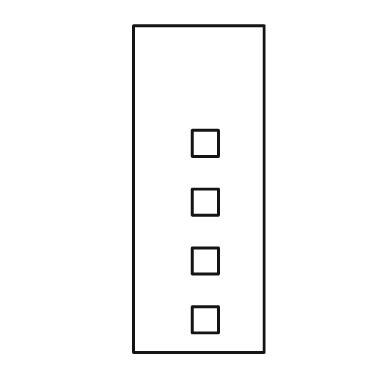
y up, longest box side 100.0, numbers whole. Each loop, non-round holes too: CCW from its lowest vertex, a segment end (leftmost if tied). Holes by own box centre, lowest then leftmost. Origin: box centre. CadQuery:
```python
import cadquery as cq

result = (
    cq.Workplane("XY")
    .moveTo(-20.0, -50.0)
    .lineTo(20.0, -50.0)
    .lineTo(20.0, 50.0)
    .lineTo(-20.0, 50.0)
    .close()
    .moveTo(-2.0, -44.0)
    .lineTo(6.0, -44.0)
    .lineTo(6.0, -36.0)
    .lineTo(-2.0, -36.0)
    .close()
    .moveTo(-2.0, -26.0)
    .lineTo(6.0, -26.0)
    .lineTo(6.0, -18.0)
    .lineTo(-2.0, -18.0)
    .close()
    .moveTo(-2.0, -8.0)
    .lineTo(6.0, -8.0)
    .lineTo(6.0, 0.0)
    .lineTo(-2.0, 0.0)
    .close()
    .moveTo(-2.0, 10.0)
    .lineTo(6.0, 10.0)
    .lineTo(6.0, 18.0)
    .lineTo(-2.0, 18.0)
    .close()
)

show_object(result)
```